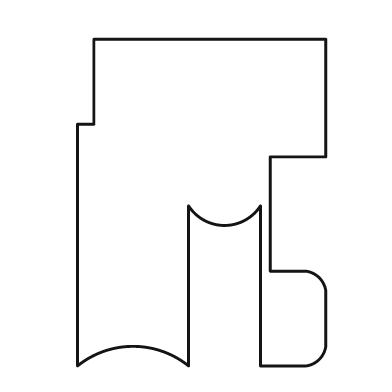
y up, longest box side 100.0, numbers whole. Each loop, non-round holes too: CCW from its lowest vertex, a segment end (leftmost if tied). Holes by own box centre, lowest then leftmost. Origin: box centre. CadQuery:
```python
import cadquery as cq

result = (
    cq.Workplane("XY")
    .moveTo(-38.0, -50.0)
    .threePointArc((-21.0, -44.0), (-4.0, -50.0))
    .lineTo(-4.0, -1.0)
    .threePointArc((7.0, -7.0), (18.0, -1.0))
    .lineTo(18.0, -50.0)
    .lineTo(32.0, -50.0)
    .threePointArc((36.0, -48.0), (38.0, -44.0))
    .lineTo(38.0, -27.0)
    .threePointArc((36.0, -23.0), (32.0, -21.0))
    .lineTo(21.0, -21.0)
    .lineTo(21.0, 14.0)
    .lineTo(38.0, 14.0)
    .lineTo(38.0, 50.0)
    .lineTo(-33.0, 50.0)
    .lineTo(-33.0, 24.0)
    .lineTo(-38.0, 24.0)
    .close()
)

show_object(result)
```